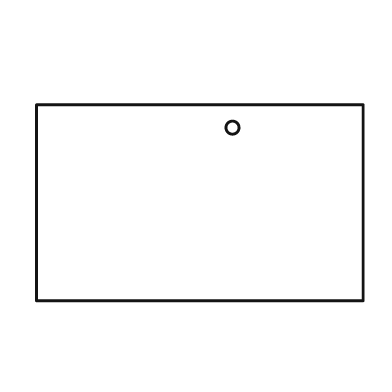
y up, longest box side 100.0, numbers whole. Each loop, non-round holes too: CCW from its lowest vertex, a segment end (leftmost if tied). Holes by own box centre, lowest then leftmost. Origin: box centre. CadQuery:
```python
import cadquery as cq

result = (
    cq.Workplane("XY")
    .moveTo(-50.0, -30.0)
    .lineTo(50.0, -30.0)
    .lineTo(50.0, 30.0)
    .lineTo(-50.0, 30.0)
    .close()
    .moveTo(10.0, 23.0)
    .circle(2.0)
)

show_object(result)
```